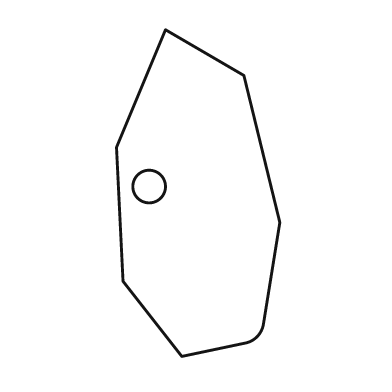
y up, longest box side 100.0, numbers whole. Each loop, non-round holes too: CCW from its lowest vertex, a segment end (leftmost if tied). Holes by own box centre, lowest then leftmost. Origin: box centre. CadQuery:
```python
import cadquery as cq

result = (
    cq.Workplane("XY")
    .moveTo(-5.0, -50.0)
    .lineTo(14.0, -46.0)
    .threePointArc((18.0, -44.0), (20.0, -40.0))
    .lineTo(25.0, -9.0)
    .lineTo(14.0, 36.0)
    .lineTo(-10.0, 50.0)
    .lineTo(-25.0, 14.0)
    .lineTo(-23.0, -27.0)
    .close()
    .moveTo(-15.0, 2.0)
    .circle(5.0)
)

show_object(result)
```